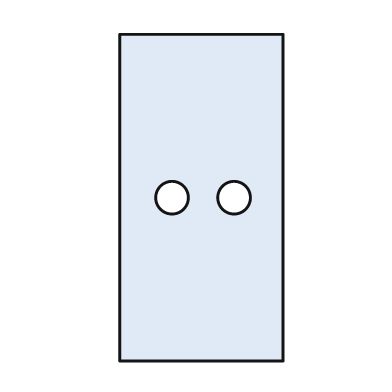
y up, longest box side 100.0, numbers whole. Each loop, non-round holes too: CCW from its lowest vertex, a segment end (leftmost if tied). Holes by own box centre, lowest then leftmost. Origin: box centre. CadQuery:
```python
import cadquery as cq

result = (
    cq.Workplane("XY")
    .moveTo(-25.0, -50.0)
    .lineTo(25.0, -50.0)
    .lineTo(25.0, 50.0)
    .lineTo(-25.0, 50.0)
    .close()
    .moveTo(-9.0, 0.0)
    .circle(5.0)
    .moveTo(10.0, 0.0)
    .circle(5.0)
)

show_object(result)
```